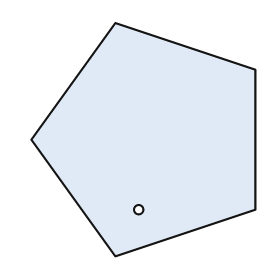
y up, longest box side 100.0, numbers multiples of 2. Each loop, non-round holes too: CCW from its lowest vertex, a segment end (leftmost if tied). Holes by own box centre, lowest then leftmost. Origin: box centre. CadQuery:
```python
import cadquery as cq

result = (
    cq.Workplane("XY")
    .moveTo(-12.0, -50.0)
    .lineTo(48.0, -30.0)
    .lineTo(48.0, 30.0)
    .lineTo(-12.0, 50.0)
    .lineTo(-48.0, 0.0)
    .close()
    .moveTo(-2.0, -30.0)
    .circle(2.0)
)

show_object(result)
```